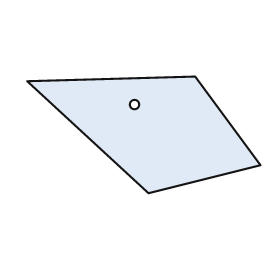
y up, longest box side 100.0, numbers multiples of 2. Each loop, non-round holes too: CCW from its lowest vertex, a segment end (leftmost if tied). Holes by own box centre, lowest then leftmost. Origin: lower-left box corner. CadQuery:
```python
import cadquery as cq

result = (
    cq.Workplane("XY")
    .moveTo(52.0, 0.0)
    .lineTo(100.0, 12.0)
    .lineTo(72.0, 50.0)
    .lineTo(0.0, 48.0)
    .close()
    .moveTo(46.0, 38.0)
    .circle(2.0)
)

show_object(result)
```